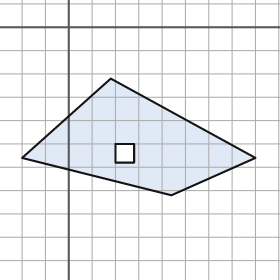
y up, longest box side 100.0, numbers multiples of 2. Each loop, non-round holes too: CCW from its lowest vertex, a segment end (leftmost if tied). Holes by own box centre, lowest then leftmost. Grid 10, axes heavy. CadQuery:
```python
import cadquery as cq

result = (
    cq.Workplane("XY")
    .moveTo(44.0, -72.0)
    .lineTo(80.0, -56.0)
    .lineTo(18.0, -22.0)
    .lineTo(-20.0, -56.0)
    .close()
    .moveTo(20.0, -58.0)
    .lineTo(28.0, -58.0)
    .lineTo(28.0, -50.0)
    .lineTo(20.0, -50.0)
    .close()
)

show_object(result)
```